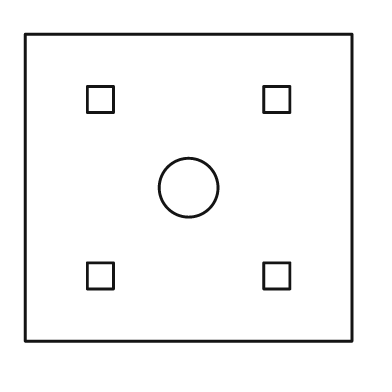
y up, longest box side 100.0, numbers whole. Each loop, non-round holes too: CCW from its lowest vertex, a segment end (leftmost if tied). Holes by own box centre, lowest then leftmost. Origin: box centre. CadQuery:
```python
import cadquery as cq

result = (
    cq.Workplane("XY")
    .moveTo(-50.0, -47.0)
    .lineTo(50.0, -47.0)
    .lineTo(50.0, 47.0)
    .lineTo(-50.0, 47.0)
    .close()
    .moveTo(-31.0, -31.0)
    .lineTo(-23.0, -31.0)
    .lineTo(-23.0, -23.0)
    .lineTo(-31.0, -23.0)
    .close()
    .moveTo(23.0, -31.0)
    .lineTo(31.0, -31.0)
    .lineTo(31.0, -23.0)
    .lineTo(23.0, -23.0)
    .close()
    .moveTo(0.0, 0.0)
    .circle(9.0)
    .moveTo(-31.0, 23.0)
    .lineTo(-23.0, 23.0)
    .lineTo(-23.0, 31.0)
    .lineTo(-31.0, 31.0)
    .close()
    .moveTo(23.0, 23.0)
    .lineTo(31.0, 23.0)
    .lineTo(31.0, 31.0)
    .lineTo(23.0, 31.0)
    .close()
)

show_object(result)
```